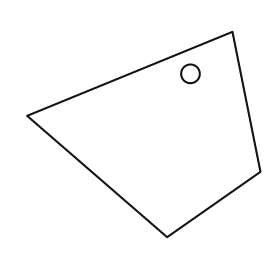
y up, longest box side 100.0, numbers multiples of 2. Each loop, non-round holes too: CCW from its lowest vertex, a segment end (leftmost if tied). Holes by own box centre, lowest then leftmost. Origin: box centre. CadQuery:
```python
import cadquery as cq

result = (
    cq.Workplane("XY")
    .moveTo(10.0, -44.0)
    .lineTo(50.0, -16.0)
    .lineTo(38.0, 44.0)
    .lineTo(-50.0, 8.0)
    .close()
    .moveTo(20.0, 26.0)
    .circle(4.0)
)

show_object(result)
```